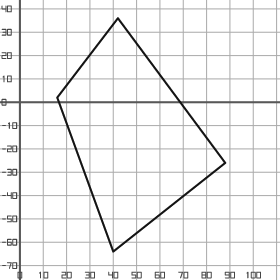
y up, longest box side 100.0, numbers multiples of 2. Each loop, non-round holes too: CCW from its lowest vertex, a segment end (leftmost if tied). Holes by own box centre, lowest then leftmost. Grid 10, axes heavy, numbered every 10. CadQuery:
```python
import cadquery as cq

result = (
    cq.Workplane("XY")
    .moveTo(40.0, -64.0)
    .lineTo(88.0, -26.0)
    .lineTo(42.0, 36.0)
    .lineTo(16.0, 2.0)
    .close()
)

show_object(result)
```